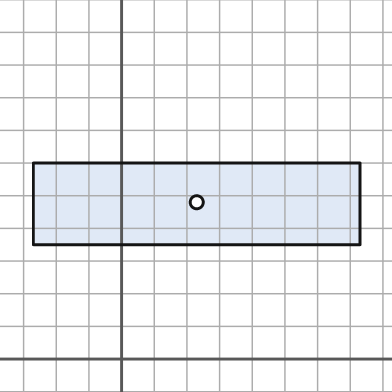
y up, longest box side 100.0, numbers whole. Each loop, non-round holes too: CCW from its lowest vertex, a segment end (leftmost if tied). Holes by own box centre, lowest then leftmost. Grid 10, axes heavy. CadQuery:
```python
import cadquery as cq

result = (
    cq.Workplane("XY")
    .moveTo(-27.0, 35.0)
    .lineTo(73.0, 35.0)
    .lineTo(73.0, 60.0)
    .lineTo(-27.0, 60.0)
    .close()
    .moveTo(23.0, 48.0)
    .circle(2.0)
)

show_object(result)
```